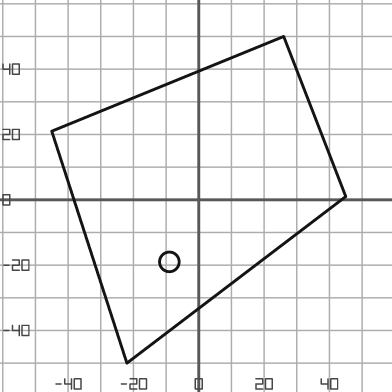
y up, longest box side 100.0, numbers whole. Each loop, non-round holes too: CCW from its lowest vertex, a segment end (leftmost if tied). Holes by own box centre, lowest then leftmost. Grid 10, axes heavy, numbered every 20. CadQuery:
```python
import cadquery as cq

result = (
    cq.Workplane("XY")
    .moveTo(-22.0, -50.0)
    .lineTo(45.0, 1.0)
    .lineTo(26.0, 50.0)
    .lineTo(-45.0, 21.0)
    .close()
    .moveTo(-9.0, -19.0)
    .circle(3.0)
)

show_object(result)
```